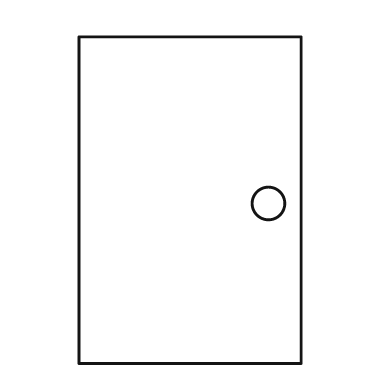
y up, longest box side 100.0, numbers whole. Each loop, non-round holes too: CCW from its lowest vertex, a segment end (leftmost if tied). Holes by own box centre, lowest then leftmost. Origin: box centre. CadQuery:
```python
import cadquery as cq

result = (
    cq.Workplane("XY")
    .moveTo(-34.0, -50.0)
    .lineTo(34.0, -50.0)
    .lineTo(34.0, 50.0)
    .lineTo(-34.0, 50.0)
    .close()
    .moveTo(24.0, -1.0)
    .circle(5.0)
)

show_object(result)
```